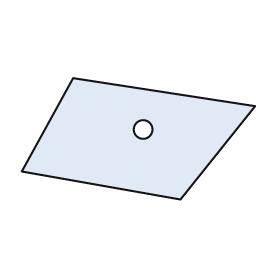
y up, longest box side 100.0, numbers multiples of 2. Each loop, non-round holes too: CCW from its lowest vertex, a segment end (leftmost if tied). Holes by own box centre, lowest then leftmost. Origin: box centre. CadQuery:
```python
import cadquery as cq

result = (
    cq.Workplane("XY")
    .moveTo(18.0, -26.0)
    .lineTo(50.0, 14.0)
    .lineTo(-28.0, 26.0)
    .lineTo(-50.0, -14.0)
    .close()
    .moveTo(2.0, 4.0)
    .circle(4.0)
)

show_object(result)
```